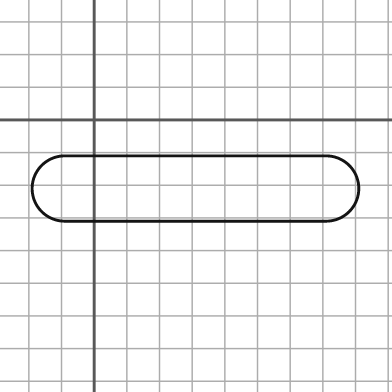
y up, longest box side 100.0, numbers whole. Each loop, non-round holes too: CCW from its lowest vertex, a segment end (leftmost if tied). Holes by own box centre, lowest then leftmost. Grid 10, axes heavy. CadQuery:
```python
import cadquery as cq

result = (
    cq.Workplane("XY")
    .moveTo(-9.0, -31.0)
    .lineTo(71.0, -31.0)
    .threePointArc((81.0, -21.0), (71.0, -11.0))
    .lineTo(-9.0, -11.0)
    .threePointArc((-19.0, -21.0), (-9.0, -31.0))
    .close()
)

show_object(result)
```